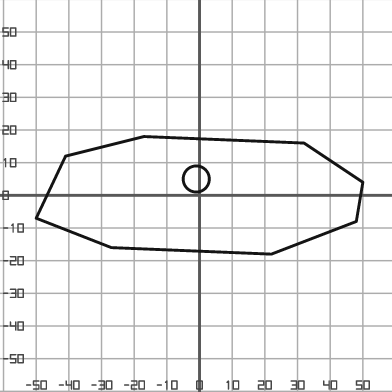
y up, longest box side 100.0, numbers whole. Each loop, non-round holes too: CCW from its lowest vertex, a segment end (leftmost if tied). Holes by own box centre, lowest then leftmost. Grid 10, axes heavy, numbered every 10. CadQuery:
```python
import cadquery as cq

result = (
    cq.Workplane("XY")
    .moveTo(22.0, -18.0)
    .lineTo(48.0, -8.0)
    .lineTo(50.0, 4.0)
    .lineTo(32.0, 16.0)
    .lineTo(-17.0, 18.0)
    .lineTo(-41.0, 12.0)
    .lineTo(-50.0, -7.0)
    .lineTo(-27.0, -16.0)
    .close()
    .moveTo(-1.0, 5.0)
    .circle(4.0)
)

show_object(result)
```